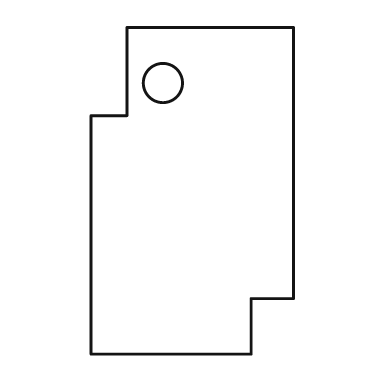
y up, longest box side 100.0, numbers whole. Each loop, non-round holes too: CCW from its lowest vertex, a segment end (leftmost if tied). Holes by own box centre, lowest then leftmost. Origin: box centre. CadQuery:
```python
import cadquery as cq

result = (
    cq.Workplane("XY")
    .moveTo(-31.0, -50.0)
    .lineTo(18.0, -50.0)
    .lineTo(18.0, -33.0)
    .lineTo(31.0, -33.0)
    .lineTo(31.0, 50.0)
    .lineTo(-20.0, 50.0)
    .lineTo(-20.0, 23.0)
    .lineTo(-31.0, 23.0)
    .close()
    .moveTo(-9.0, 33.0)
    .circle(6.0)
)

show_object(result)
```